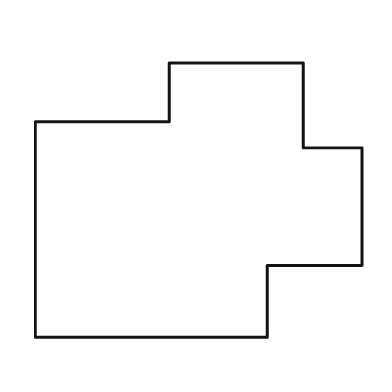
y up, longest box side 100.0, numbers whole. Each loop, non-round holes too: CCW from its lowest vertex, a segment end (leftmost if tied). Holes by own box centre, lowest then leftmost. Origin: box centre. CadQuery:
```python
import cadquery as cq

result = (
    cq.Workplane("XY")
    .moveTo(-50.0, -42.0)
    .lineTo(21.0, -42.0)
    .lineTo(21.0, -20.0)
    .lineTo(50.0, -20.0)
    .lineTo(50.0, 16.0)
    .lineTo(32.0, 16.0)
    .lineTo(32.0, 42.0)
    .lineTo(-9.0, 42.0)
    .lineTo(-9.0, 24.0)
    .lineTo(-50.0, 24.0)
    .close()
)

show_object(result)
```